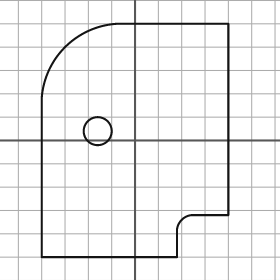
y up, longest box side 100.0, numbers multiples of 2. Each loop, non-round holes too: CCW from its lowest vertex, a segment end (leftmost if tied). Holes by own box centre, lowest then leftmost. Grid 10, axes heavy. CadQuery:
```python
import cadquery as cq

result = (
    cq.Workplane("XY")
    .moveTo(-40.0, -50.0)
    .lineTo(18.0, -50.0)
    .lineTo(18.0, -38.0)
    .threePointArc((20.0, -34.0), (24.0, -32.0))
    .lineTo(40.0, -32.0)
    .lineTo(40.0, 50.0)
    .lineTo(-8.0, 50.0)
    .threePointArc((-30.0, 40.0), (-40.0, 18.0))
    .close()
    .moveTo(-16.0, 4.0)
    .circle(6.0)
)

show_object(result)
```